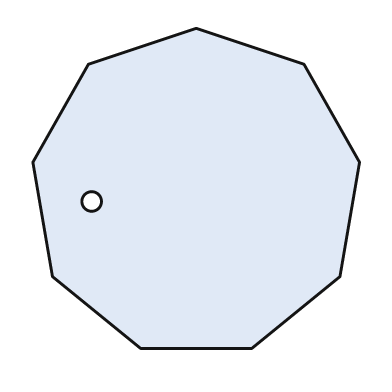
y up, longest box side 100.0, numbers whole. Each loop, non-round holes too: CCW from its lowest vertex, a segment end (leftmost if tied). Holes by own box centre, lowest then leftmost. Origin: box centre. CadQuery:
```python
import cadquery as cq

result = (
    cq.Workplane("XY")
    .moveTo(-17.0, -49.0)
    .lineTo(17.0, -49.0)
    .lineTo(44.0, -27.0)
    .lineTo(50.0, 8.0)
    .lineTo(33.0, 38.0)
    .lineTo(0.0, 49.0)
    .lineTo(-33.0, 38.0)
    .lineTo(-50.0, 8.0)
    .lineTo(-44.0, -27.0)
    .close()
    .moveTo(-32.0, -4.0)
    .circle(3.0)
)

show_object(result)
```